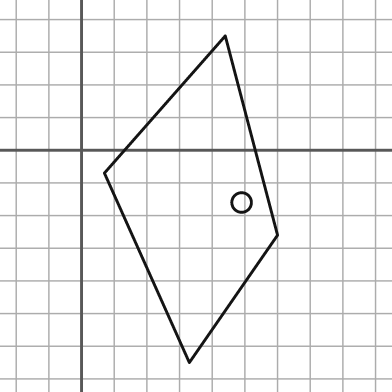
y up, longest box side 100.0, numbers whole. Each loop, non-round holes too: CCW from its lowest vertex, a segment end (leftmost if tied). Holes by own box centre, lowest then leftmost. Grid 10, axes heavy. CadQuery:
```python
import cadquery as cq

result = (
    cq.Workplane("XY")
    .moveTo(33.0, -65.0)
    .lineTo(60.0, -26.0)
    .lineTo(44.0, 35.0)
    .lineTo(7.0, -7.0)
    .close()
    .moveTo(49.0, -16.0)
    .circle(3.0)
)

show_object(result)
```